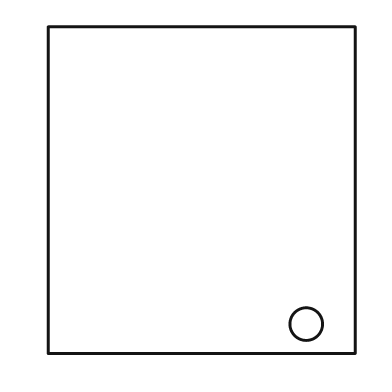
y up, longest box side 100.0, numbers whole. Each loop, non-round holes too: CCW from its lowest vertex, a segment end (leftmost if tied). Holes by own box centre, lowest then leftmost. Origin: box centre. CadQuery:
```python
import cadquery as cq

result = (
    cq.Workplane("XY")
    .moveTo(-47.0, -50.0)
    .lineTo(47.0, -50.0)
    .lineTo(47.0, 50.0)
    .lineTo(-47.0, 50.0)
    .close()
    .moveTo(32.0, -41.0)
    .circle(5.0)
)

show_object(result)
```